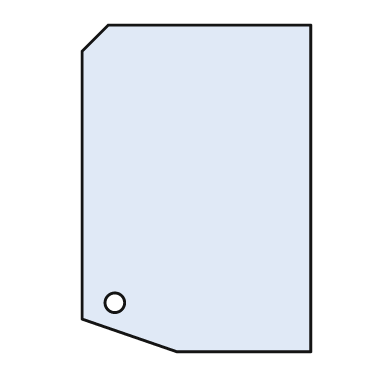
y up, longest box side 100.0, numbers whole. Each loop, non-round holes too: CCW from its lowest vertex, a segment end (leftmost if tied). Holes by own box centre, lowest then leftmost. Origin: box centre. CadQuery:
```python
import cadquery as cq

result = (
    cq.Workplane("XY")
    .moveTo(-6.0, -50.0)
    .lineTo(35.0, -50.0)
    .lineTo(35.0, 50.0)
    .lineTo(-27.0, 50.0)
    .lineTo(-35.0, 42.0)
    .lineTo(-35.0, -40.0)
    .close()
    .moveTo(-25.0, -35.0)
    .circle(3.0)
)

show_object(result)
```